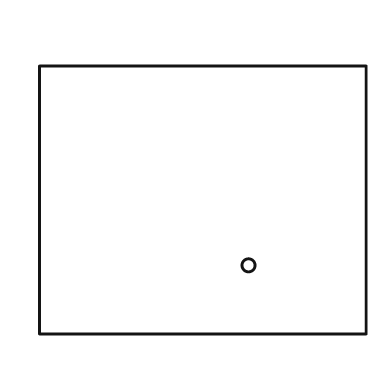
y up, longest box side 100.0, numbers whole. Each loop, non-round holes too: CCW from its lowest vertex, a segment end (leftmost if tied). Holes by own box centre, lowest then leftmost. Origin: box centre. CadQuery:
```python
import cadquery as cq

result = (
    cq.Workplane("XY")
    .moveTo(-50.0, -41.0)
    .lineTo(50.0, -41.0)
    .lineTo(50.0, 41.0)
    .lineTo(-50.0, 41.0)
    .close()
    .moveTo(14.0, -20.0)
    .circle(2.0)
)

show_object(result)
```